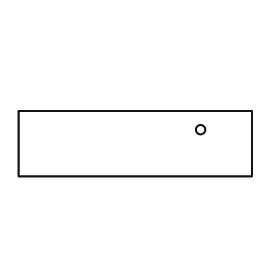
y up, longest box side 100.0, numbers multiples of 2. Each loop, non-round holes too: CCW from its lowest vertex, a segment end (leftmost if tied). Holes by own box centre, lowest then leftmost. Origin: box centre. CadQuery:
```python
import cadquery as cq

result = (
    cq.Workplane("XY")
    .moveTo(-50.0, -14.0)
    .lineTo(50.0, -14.0)
    .lineTo(50.0, 14.0)
    .lineTo(-50.0, 14.0)
    .close()
    .moveTo(28.0, 6.0)
    .circle(2.0)
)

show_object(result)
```